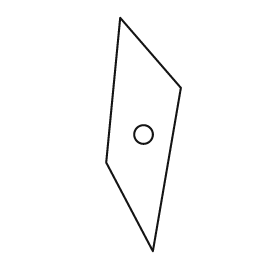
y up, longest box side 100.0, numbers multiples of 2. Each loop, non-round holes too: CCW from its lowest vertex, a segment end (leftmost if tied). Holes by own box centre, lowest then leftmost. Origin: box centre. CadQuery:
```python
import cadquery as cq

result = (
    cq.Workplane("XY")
    .moveTo(4.0, -50.0)
    .lineTo(16.0, 20.0)
    .lineTo(-10.0, 50.0)
    .lineTo(-16.0, -12.0)
    .close()
    .moveTo(0.0, 0.0)
    .circle(4.0)
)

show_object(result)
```